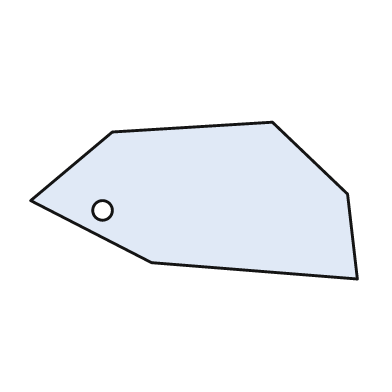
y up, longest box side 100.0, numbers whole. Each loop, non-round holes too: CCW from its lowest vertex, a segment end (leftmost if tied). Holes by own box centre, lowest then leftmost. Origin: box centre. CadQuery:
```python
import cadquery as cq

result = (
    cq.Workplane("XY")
    .moveTo(50.0, -24.0)
    .lineTo(47.0, 2.0)
    .lineTo(24.0, 24.0)
    .lineTo(-25.0, 21.0)
    .lineTo(-50.0, 0.0)
    .lineTo(-13.0, -19.0)
    .close()
    .moveTo(-28.0, -3.0)
    .circle(3.0)
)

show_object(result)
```